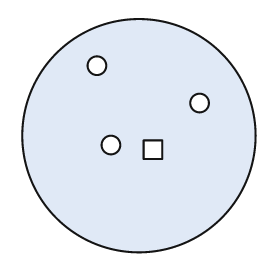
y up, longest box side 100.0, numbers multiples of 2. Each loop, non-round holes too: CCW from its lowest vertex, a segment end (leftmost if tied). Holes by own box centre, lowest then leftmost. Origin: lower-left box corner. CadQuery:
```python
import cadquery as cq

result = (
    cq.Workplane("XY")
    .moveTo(50.0, 50.0)
    .circle(50.0)
    .moveTo(52.0, 40.0)
    .lineTo(60.0, 40.0)
    .lineTo(60.0, 48.0)
    .lineTo(52.0, 48.0)
    .close()
    .moveTo(38.0, 46.0)
    .circle(4.0)
    .moveTo(76.0, 64.0)
    .circle(4.0)
    .moveTo(32.0, 80.0)
    .circle(4.0)
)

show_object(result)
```